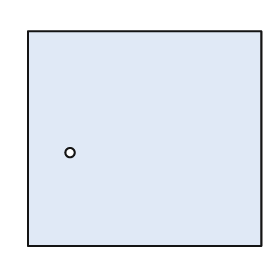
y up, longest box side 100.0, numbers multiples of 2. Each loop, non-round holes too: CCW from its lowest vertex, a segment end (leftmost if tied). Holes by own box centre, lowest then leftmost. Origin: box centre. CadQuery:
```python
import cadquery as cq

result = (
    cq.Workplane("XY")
    .moveTo(-50.0, -46.0)
    .lineTo(50.0, -46.0)
    .lineTo(50.0, 46.0)
    .lineTo(-50.0, 46.0)
    .close()
    .moveTo(-32.0, -6.0)
    .circle(2.0)
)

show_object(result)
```